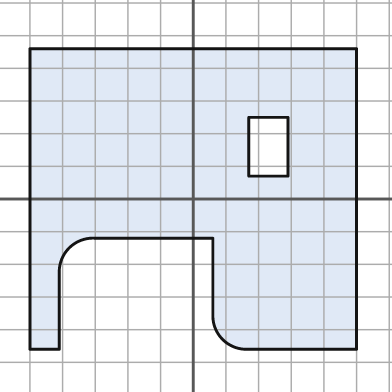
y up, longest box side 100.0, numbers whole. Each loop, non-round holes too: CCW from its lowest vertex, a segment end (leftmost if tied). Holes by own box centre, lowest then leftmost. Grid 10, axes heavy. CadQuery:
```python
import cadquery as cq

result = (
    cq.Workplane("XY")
    .moveTo(-50.0, -46.0)
    .lineTo(-41.0, -46.0)
    .lineTo(-41.0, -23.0)
    .threePointArc((-38.0, -15.0), (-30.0, -12.0))
    .lineTo(6.0, -12.0)
    .lineTo(6.0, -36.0)
    .threePointArc((9.0, -43.0), (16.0, -46.0))
    .lineTo(50.0, -46.0)
    .lineTo(50.0, 46.0)
    .lineTo(-50.0, 46.0)
    .close()
    .moveTo(17.0, 7.0)
    .lineTo(29.0, 7.0)
    .lineTo(29.0, 25.0)
    .lineTo(17.0, 25.0)
    .close()
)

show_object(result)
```